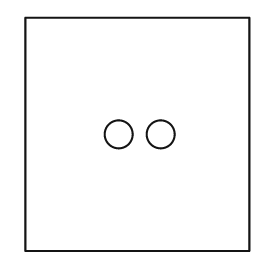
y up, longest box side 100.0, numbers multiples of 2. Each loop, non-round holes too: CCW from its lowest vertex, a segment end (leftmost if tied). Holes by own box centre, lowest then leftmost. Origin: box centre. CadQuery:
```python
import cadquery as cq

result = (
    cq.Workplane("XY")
    .moveTo(-48.0, -50.0)
    .lineTo(48.0, -50.0)
    .lineTo(48.0, 50.0)
    .lineTo(-48.0, 50.0)
    .close()
    .moveTo(-8.0, 0.0)
    .circle(6.0)
    .moveTo(10.0, 0.0)
    .circle(6.0)
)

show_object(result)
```